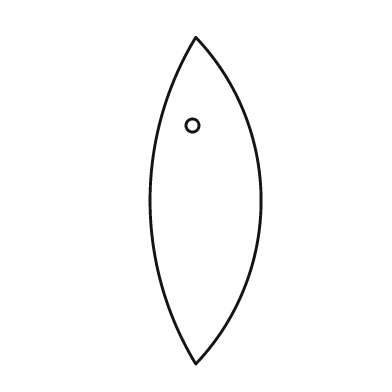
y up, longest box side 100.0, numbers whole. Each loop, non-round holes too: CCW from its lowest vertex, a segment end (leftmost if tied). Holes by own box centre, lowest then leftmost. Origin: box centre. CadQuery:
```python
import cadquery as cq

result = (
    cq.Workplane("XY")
    .moveTo(-3.0, -50.0)
    .threePointArc((17.0, 0.0), (-3.0, 50.0))
    .threePointArc((-17.0, 0.0), (-3.0, -50.0))
    .close()
    .moveTo(-4.0, 23.0)
    .circle(2.0)
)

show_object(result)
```